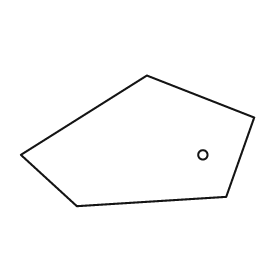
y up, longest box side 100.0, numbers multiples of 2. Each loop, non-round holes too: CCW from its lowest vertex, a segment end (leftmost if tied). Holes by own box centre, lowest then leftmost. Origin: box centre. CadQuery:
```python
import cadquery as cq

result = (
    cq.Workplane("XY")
    .moveTo(-26.0, -28.0)
    .lineTo(38.0, -24.0)
    .lineTo(50.0, 10.0)
    .lineTo(4.0, 28.0)
    .lineTo(-50.0, -6.0)
    .close()
    .moveTo(28.0, -6.0)
    .circle(2.0)
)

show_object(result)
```